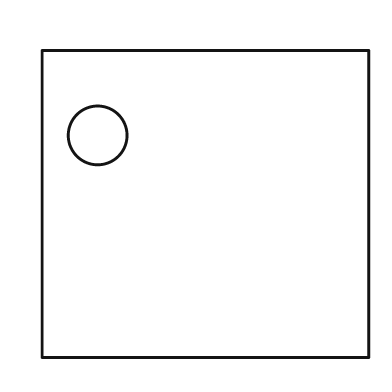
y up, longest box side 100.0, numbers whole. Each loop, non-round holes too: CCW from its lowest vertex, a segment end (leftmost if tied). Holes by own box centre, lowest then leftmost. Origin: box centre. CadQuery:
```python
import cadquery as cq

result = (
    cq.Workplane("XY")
    .moveTo(-50.0, -47.0)
    .lineTo(50.0, -47.0)
    .lineTo(50.0, 47.0)
    .lineTo(-50.0, 47.0)
    .close()
    .moveTo(-33.0, 21.0)
    .circle(9.0)
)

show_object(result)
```